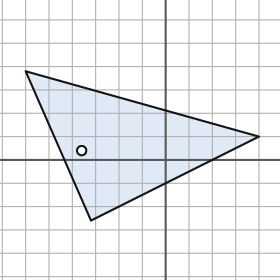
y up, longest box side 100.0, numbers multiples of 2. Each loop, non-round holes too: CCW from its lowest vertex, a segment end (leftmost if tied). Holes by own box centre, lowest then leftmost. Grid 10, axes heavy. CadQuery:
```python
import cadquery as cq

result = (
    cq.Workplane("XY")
    .moveTo(-32.0, -26.0)
    .lineTo(40.0, 10.0)
    .lineTo(-60.0, 38.0)
    .close()
    .moveTo(-36.0, 4.0)
    .circle(2.0)
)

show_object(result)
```